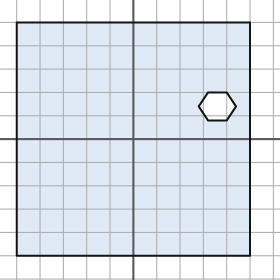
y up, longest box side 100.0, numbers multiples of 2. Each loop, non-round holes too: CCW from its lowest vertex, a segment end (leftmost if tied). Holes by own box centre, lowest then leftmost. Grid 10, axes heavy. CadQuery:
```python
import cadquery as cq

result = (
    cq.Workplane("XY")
    .moveTo(-50.0, -50.0)
    .lineTo(50.0, -50.0)
    .lineTo(50.0, 50.0)
    .lineTo(-50.0, 50.0)
    .close()
    .moveTo(32.0, 8.0)
    .lineTo(40.0, 8.0)
    .lineTo(44.0, 14.0)
    .lineTo(40.0, 20.0)
    .lineTo(32.0, 20.0)
    .lineTo(28.0, 14.0)
    .close()
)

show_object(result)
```